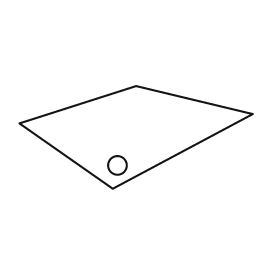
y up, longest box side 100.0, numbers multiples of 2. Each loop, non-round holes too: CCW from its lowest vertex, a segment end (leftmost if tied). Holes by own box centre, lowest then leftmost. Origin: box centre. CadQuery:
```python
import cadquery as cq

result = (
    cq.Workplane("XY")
    .moveTo(-10.0, -22.0)
    .lineTo(50.0, 10.0)
    .lineTo(0.0, 22.0)
    .lineTo(-50.0, 6.0)
    .close()
    .moveTo(-8.0, -12.0)
    .circle(4.0)
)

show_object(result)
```